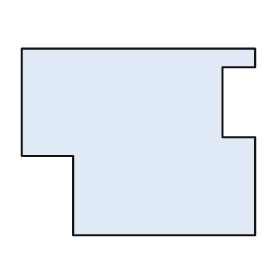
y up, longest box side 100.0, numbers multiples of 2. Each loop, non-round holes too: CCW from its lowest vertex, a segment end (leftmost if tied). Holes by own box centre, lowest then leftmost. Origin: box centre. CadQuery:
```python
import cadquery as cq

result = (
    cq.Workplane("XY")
    .moveTo(-28.0, -40.0)
    .lineTo(50.0, -40.0)
    .lineTo(50.0, 2.0)
    .lineTo(36.0, 2.0)
    .lineTo(36.0, 32.0)
    .lineTo(50.0, 32.0)
    .lineTo(50.0, 40.0)
    .lineTo(-50.0, 40.0)
    .lineTo(-50.0, -6.0)
    .lineTo(-28.0, -6.0)
    .close()
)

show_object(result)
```